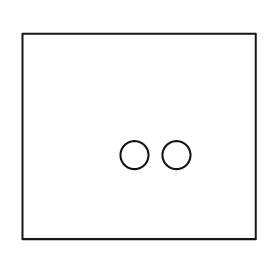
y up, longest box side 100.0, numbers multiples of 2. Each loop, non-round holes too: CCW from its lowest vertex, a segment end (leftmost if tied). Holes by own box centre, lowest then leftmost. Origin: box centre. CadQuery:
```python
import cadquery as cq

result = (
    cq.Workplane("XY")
    .moveTo(-50.0, -44.0)
    .lineTo(50.0, -44.0)
    .lineTo(50.0, 44.0)
    .lineTo(-50.0, 44.0)
    .close()
    .moveTo(-2.0, -8.0)
    .circle(6.0)
    .moveTo(16.0, -8.0)
    .circle(6.0)
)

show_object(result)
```